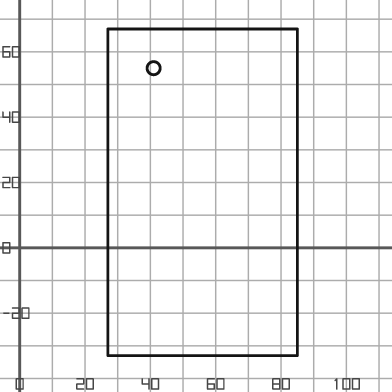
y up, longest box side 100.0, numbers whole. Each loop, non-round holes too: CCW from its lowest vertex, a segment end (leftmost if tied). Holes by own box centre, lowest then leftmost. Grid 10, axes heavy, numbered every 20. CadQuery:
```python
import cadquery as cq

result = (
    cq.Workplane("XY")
    .moveTo(27.0, -33.0)
    .lineTo(85.0, -33.0)
    .lineTo(85.0, 67.0)
    .lineTo(27.0, 67.0)
    .close()
    .moveTo(41.0, 55.0)
    .circle(2.0)
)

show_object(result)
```